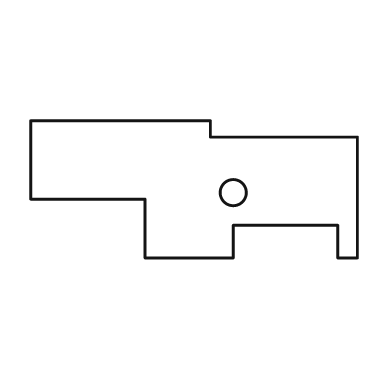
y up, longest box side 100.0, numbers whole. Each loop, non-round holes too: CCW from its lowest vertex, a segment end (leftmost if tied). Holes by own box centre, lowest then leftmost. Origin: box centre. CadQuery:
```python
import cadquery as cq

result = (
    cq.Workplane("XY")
    .moveTo(-15.0, -21.0)
    .lineTo(12.0, -21.0)
    .lineTo(12.0, -11.0)
    .lineTo(44.0, -11.0)
    .lineTo(44.0, -21.0)
    .lineTo(50.0, -21.0)
    .lineTo(50.0, 16.0)
    .lineTo(5.0, 16.0)
    .lineTo(5.0, 21.0)
    .lineTo(-50.0, 21.0)
    .lineTo(-50.0, -3.0)
    .lineTo(-15.0, -3.0)
    .close()
    .moveTo(12.0, -1.0)
    .circle(4.0)
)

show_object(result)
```